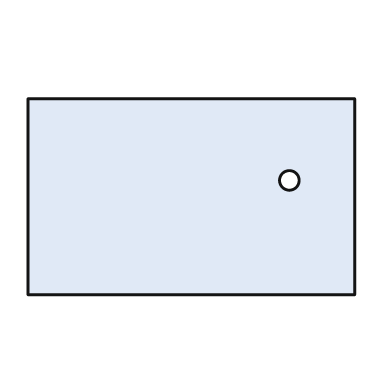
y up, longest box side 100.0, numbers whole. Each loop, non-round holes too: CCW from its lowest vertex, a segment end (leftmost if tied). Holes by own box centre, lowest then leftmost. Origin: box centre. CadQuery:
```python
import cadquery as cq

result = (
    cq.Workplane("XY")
    .moveTo(-50.0, -30.0)
    .lineTo(50.0, -30.0)
    .lineTo(50.0, 30.0)
    .lineTo(-50.0, 30.0)
    .close()
    .moveTo(30.0, 5.0)
    .circle(3.0)
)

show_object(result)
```